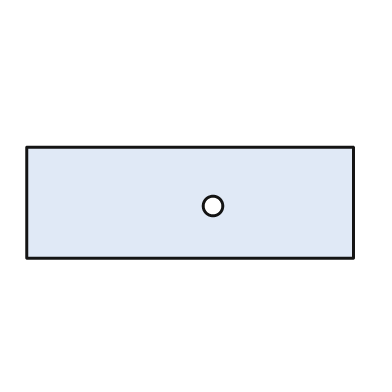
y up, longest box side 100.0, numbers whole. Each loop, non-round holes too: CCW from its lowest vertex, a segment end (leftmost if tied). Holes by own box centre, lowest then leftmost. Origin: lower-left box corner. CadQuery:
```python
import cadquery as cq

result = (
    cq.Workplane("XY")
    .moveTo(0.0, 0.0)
    .lineTo(100.0, 0.0)
    .lineTo(100.0, 34.0)
    .lineTo(0.0, 34.0)
    .close()
    .moveTo(57.0, 16.0)
    .circle(3.0)
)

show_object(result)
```